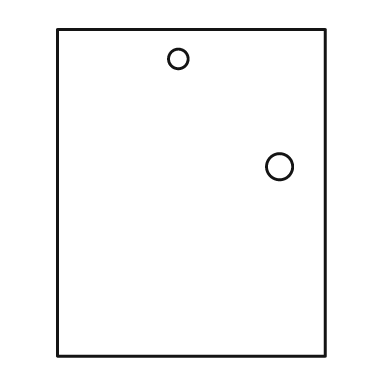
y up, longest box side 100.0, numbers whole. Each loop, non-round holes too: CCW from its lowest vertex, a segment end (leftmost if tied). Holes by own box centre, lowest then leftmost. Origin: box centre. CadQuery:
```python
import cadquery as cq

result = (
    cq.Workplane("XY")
    .moveTo(-41.0, -50.0)
    .lineTo(41.0, -50.0)
    .lineTo(41.0, 50.0)
    .lineTo(-41.0, 50.0)
    .close()
    .moveTo(27.0, 8.0)
    .circle(4.0)
    .moveTo(-4.0, 41.0)
    .circle(3.0)
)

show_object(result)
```